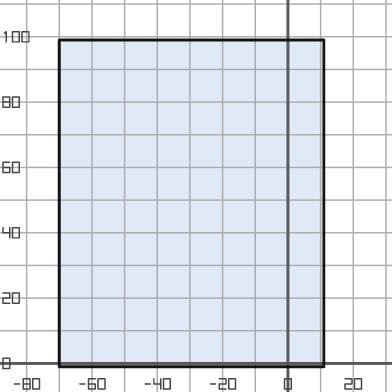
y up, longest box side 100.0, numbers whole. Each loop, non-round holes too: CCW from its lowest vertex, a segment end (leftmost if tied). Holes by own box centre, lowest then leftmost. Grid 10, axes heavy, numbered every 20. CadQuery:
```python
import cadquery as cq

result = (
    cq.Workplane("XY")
    .moveTo(-70.0, -1.0)
    .lineTo(11.0, -1.0)
    .lineTo(11.0, 99.0)
    .lineTo(-70.0, 99.0)
    .close()
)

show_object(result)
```